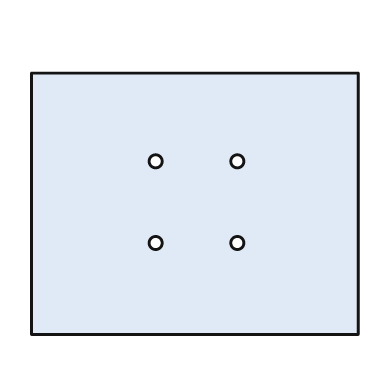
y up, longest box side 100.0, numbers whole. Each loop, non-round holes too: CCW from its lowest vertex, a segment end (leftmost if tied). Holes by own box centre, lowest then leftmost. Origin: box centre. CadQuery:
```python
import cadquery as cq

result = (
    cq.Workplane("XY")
    .moveTo(-50.0, -40.0)
    .lineTo(50.0, -40.0)
    .lineTo(50.0, 40.0)
    .lineTo(-50.0, 40.0)
    .close()
    .moveTo(-12.0, -12.0)
    .circle(2.0)
    .moveTo(13.0, -12.0)
    .circle(2.0)
    .moveTo(-12.0, 13.0)
    .circle(2.0)
    .moveTo(13.0, 13.0)
    .circle(2.0)
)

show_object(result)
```